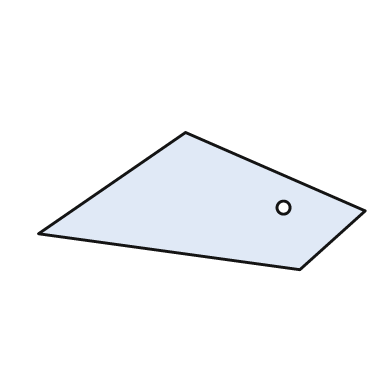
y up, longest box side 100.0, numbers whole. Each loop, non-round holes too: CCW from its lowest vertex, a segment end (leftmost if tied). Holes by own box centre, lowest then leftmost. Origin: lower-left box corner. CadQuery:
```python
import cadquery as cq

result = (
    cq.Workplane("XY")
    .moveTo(80.0, 0.0)
    .lineTo(100.0, 18.0)
    .lineTo(45.0, 42.0)
    .lineTo(0.0, 11.0)
    .close()
    .moveTo(75.0, 19.0)
    .circle(2.0)
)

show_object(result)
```